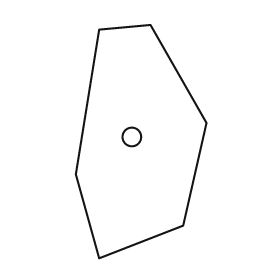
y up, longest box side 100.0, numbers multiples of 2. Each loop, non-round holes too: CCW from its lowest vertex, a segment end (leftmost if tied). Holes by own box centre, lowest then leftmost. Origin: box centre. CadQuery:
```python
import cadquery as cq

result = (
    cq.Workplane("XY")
    .moveTo(-18.0, -50.0)
    .lineTo(18.0, -36.0)
    .lineTo(28.0, 8.0)
    .lineTo(4.0, 50.0)
    .lineTo(-18.0, 48.0)
    .lineTo(-28.0, -14.0)
    .close()
    .moveTo(-4.0, 2.0)
    .circle(4.0)
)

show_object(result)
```